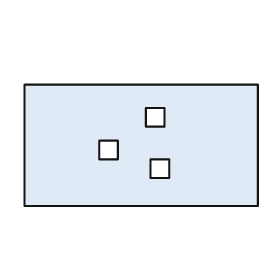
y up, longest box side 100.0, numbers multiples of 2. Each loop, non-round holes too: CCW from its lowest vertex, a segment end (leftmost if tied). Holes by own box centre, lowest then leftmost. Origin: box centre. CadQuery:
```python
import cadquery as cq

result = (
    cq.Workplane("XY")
    .moveTo(-50.0, -26.0)
    .lineTo(50.0, -26.0)
    .lineTo(50.0, 26.0)
    .lineTo(-50.0, 26.0)
    .close()
    .moveTo(4.0, -14.0)
    .lineTo(12.0, -14.0)
    .lineTo(12.0, -6.0)
    .lineTo(4.0, -6.0)
    .close()
    .moveTo(-18.0, -6.0)
    .lineTo(-10.0, -6.0)
    .lineTo(-10.0, 2.0)
    .lineTo(-18.0, 2.0)
    .close()
    .moveTo(2.0, 8.0)
    .lineTo(10.0, 8.0)
    .lineTo(10.0, 16.0)
    .lineTo(2.0, 16.0)
    .close()
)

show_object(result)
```